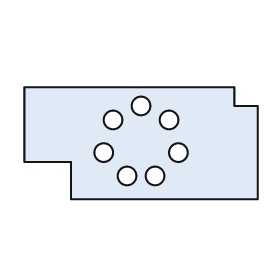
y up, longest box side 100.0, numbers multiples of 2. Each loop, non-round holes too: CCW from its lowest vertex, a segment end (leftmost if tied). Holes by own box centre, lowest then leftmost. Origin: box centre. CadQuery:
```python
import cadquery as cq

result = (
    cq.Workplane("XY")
    .moveTo(-30.0, -24.0)
    .lineTo(50.0, -24.0)
    .lineTo(50.0, 16.0)
    .lineTo(40.0, 16.0)
    .lineTo(40.0, 24.0)
    .lineTo(-50.0, 24.0)
    .lineTo(-50.0, -8.0)
    .lineTo(-30.0, -8.0)
    .close()
    .moveTo(-6.0, -14.0)
    .circle(4.0)
    .moveTo(6.0, -14.0)
    .circle(4.0)
    .moveTo(-16.0, -4.0)
    .circle(4.0)
    .moveTo(16.0, -4.0)
    .circle(4.0)
    .moveTo(-12.0, 10.0)
    .circle(4.0)
    .moveTo(12.0, 10.0)
    .circle(4.0)
    .moveTo(0.0, 16.0)
    .circle(4.0)
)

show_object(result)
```